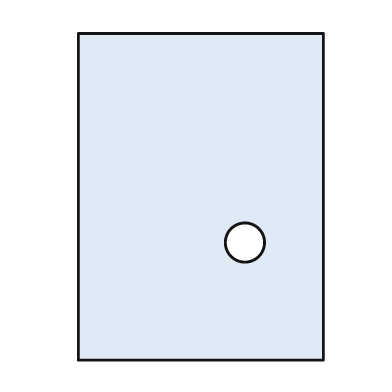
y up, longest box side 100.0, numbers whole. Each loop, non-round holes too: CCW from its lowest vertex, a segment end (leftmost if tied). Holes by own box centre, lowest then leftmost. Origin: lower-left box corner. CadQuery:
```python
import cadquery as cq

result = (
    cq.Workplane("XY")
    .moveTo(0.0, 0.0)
    .lineTo(75.0, 0.0)
    .lineTo(75.0, 100.0)
    .lineTo(0.0, 100.0)
    .close()
    .moveTo(51.0, 36.0)
    .circle(6.0)
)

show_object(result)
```